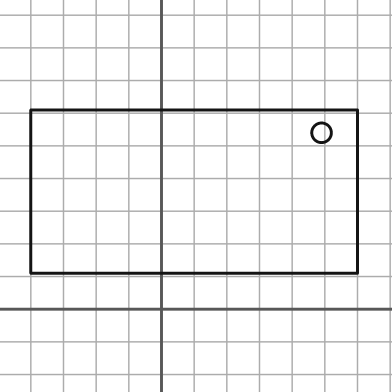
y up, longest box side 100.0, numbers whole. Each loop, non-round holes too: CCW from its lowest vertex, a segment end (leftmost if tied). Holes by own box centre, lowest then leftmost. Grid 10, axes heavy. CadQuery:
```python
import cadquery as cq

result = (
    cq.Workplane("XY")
    .moveTo(-40.0, 11.0)
    .lineTo(60.0, 11.0)
    .lineTo(60.0, 61.0)
    .lineTo(-40.0, 61.0)
    .close()
    .moveTo(49.0, 54.0)
    .circle(3.0)
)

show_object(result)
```